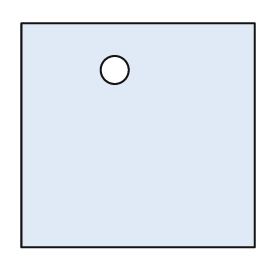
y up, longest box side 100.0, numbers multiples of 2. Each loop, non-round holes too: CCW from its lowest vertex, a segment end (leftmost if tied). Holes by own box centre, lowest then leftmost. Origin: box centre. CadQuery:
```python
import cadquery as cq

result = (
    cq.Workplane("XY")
    .moveTo(-50.0, -48.0)
    .lineTo(50.0, -48.0)
    .lineTo(50.0, 48.0)
    .lineTo(-50.0, 48.0)
    .close()
    .moveTo(-10.0, 28.0)
    .circle(6.0)
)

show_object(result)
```